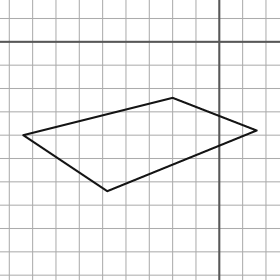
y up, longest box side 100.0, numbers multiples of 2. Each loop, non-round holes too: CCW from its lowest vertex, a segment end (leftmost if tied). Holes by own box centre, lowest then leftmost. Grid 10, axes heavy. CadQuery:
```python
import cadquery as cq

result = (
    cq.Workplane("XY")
    .moveTo(-48.0, -64.0)
    .lineTo(16.0, -38.0)
    .lineTo(-20.0, -24.0)
    .lineTo(-84.0, -40.0)
    .close()
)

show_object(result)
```